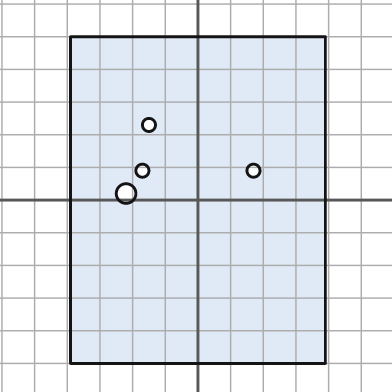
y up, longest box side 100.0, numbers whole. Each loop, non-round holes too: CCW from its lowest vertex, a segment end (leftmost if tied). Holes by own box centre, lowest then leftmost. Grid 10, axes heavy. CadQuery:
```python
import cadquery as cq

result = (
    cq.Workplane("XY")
    .moveTo(-39.0, -50.0)
    .lineTo(39.0, -50.0)
    .lineTo(39.0, 50.0)
    .lineTo(-39.0, 50.0)
    .close()
    .moveTo(-22.0, 2.0)
    .circle(3.0)
    .moveTo(-17.0, 9.0)
    .circle(2.0)
    .moveTo(17.0, 9.0)
    .circle(2.0)
    .moveTo(-15.0, 23.0)
    .circle(2.0)
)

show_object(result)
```